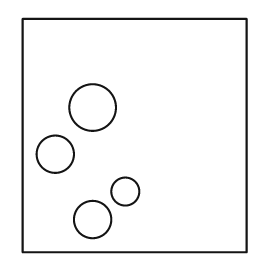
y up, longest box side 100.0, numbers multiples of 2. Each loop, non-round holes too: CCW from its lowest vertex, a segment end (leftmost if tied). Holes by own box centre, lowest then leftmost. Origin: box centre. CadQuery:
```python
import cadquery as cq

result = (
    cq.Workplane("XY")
    .moveTo(-48.0, -50.0)
    .lineTo(48.0, -50.0)
    .lineTo(48.0, 50.0)
    .lineTo(-48.0, 50.0)
    .close()
    .moveTo(-18.0, -36.0)
    .circle(8.0)
    .moveTo(-4.0, -24.0)
    .circle(6.0)
    .moveTo(-34.0, -8.0)
    .circle(8.0)
    .moveTo(-18.0, 12.0)
    .circle(10.0)
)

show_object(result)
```